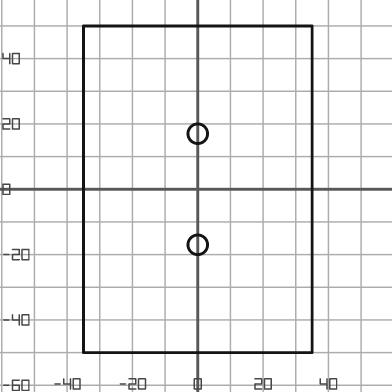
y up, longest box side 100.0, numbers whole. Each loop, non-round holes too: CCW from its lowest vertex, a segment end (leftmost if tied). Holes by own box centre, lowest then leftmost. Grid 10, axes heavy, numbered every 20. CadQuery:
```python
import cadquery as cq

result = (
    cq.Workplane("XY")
    .moveTo(-35.0, -50.0)
    .lineTo(35.0, -50.0)
    .lineTo(35.0, 50.0)
    .lineTo(-35.0, 50.0)
    .close()
    .moveTo(0.0, -17.0)
    .circle(3.0)
    .moveTo(0.0, 17.0)
    .circle(3.0)
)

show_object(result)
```